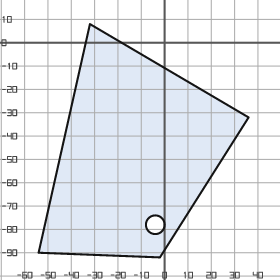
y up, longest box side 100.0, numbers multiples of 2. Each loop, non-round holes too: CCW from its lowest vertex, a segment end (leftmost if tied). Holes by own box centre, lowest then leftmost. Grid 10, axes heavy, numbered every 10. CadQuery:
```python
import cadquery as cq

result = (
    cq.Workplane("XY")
    .moveTo(-2.0, -92.0)
    .lineTo(36.0, -32.0)
    .lineTo(-32.0, 8.0)
    .lineTo(-54.0, -90.0)
    .close()
    .moveTo(-4.0, -78.0)
    .circle(4.0)
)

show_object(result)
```